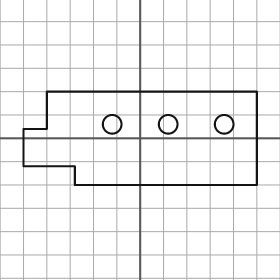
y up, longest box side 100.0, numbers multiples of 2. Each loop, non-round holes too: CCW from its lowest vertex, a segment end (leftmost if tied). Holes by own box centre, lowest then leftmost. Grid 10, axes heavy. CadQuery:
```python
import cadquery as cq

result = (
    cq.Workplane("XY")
    .moveTo(-28.0, -20.0)
    .lineTo(50.0, -20.0)
    .lineTo(50.0, 20.0)
    .lineTo(-40.0, 20.0)
    .lineTo(-40.0, 4.0)
    .lineTo(-50.0, 4.0)
    .lineTo(-50.0, -12.0)
    .lineTo(-28.0, -12.0)
    .close()
    .moveTo(-12.0, 6.0)
    .circle(4.0)
    .moveTo(12.0, 6.0)
    .circle(4.0)
    .moveTo(36.0, 6.0)
    .circle(4.0)
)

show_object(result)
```